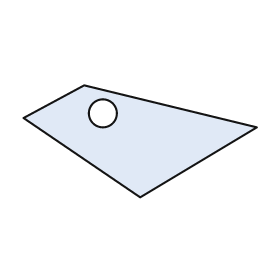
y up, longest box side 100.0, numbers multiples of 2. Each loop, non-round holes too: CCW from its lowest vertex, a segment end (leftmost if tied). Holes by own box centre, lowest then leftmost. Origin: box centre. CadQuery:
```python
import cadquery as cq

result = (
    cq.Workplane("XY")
    .moveTo(0.0, -24.0)
    .lineTo(50.0, 6.0)
    .lineTo(-24.0, 24.0)
    .lineTo(-50.0, 10.0)
    .close()
    .moveTo(-16.0, 12.0)
    .circle(6.0)
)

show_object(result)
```